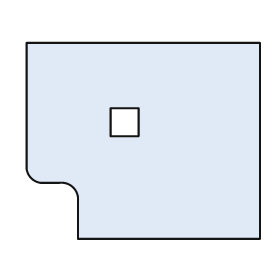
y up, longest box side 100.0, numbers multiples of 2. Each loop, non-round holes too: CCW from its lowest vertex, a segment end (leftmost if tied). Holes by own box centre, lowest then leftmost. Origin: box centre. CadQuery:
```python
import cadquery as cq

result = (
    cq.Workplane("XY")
    .moveTo(-28.0, -42.0)
    .lineTo(50.0, -42.0)
    .lineTo(50.0, 42.0)
    .lineTo(-50.0, 42.0)
    .lineTo(-50.0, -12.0)
    .threePointArc((-48.0, -16.0), (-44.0, -18.0))
    .lineTo(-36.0, -18.0)
    .threePointArc((-30.0, -20.0), (-28.0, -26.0))
    .close()
    .moveTo(-14.0, 2.0)
    .lineTo(-2.0, 2.0)
    .lineTo(-2.0, 14.0)
    .lineTo(-14.0, 14.0)
    .close()
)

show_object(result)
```